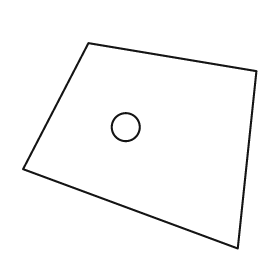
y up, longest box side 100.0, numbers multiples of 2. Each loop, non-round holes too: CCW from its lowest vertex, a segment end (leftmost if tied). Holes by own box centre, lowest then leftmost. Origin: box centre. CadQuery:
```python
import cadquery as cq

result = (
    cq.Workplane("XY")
    .moveTo(42.0, -44.0)
    .lineTo(50.0, 32.0)
    .lineTo(-22.0, 44.0)
    .lineTo(-50.0, -10.0)
    .close()
    .moveTo(-6.0, 8.0)
    .circle(6.0)
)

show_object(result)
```